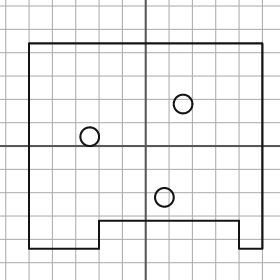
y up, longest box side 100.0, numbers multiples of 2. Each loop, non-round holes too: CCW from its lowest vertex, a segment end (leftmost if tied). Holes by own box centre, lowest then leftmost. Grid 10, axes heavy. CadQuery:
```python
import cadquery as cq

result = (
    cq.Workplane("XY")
    .moveTo(-50.0, -44.0)
    .lineTo(-20.0, -44.0)
    .lineTo(-20.0, -32.0)
    .lineTo(40.0, -32.0)
    .lineTo(40.0, -44.0)
    .lineTo(50.0, -44.0)
    .lineTo(50.0, 44.0)
    .lineTo(-50.0, 44.0)
    .close()
    .moveTo(8.0, -22.0)
    .circle(4.0)
    .moveTo(-24.0, 4.0)
    .circle(4.0)
    .moveTo(16.0, 18.0)
    .circle(4.0)
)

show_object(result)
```